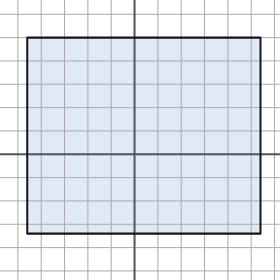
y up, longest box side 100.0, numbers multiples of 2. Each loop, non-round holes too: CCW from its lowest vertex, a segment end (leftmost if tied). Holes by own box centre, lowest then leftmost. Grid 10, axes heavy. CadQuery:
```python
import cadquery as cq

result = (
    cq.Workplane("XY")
    .moveTo(-46.0, -34.0)
    .lineTo(54.0, -34.0)
    .lineTo(54.0, 50.0)
    .lineTo(-46.0, 50.0)
    .close()
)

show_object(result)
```